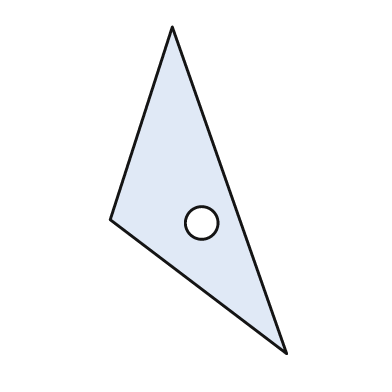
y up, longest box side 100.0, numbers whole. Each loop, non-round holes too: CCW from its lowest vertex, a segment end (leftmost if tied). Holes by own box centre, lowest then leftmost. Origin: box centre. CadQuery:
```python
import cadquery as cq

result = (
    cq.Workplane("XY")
    .moveTo(27.0, -50.0)
    .lineTo(-8.0, 50.0)
    .lineTo(-27.0, -9.0)
    .close()
    .moveTo(1.0, -10.0)
    .circle(5.0)
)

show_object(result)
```